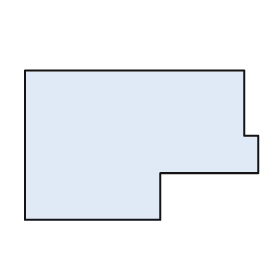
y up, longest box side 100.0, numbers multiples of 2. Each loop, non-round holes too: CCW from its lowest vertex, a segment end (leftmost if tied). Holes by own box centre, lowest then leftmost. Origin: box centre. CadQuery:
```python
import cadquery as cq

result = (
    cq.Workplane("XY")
    .moveTo(-50.0, -32.0)
    .lineTo(8.0, -32.0)
    .lineTo(8.0, -12.0)
    .lineTo(50.0, -12.0)
    .lineTo(50.0, 4.0)
    .lineTo(44.0, 4.0)
    .lineTo(44.0, 32.0)
    .lineTo(-50.0, 32.0)
    .close()
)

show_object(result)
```